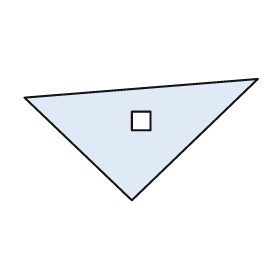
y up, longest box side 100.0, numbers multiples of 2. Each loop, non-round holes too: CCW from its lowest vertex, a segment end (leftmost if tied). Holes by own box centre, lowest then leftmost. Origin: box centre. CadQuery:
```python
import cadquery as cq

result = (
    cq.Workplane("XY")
    .moveTo(-4.0, -26.0)
    .lineTo(50.0, 26.0)
    .lineTo(-50.0, 18.0)
    .close()
    .moveTo(-4.0, 4.0)
    .lineTo(4.0, 4.0)
    .lineTo(4.0, 12.0)
    .lineTo(-4.0, 12.0)
    .close()
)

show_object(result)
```